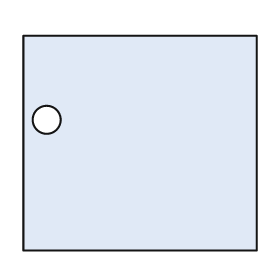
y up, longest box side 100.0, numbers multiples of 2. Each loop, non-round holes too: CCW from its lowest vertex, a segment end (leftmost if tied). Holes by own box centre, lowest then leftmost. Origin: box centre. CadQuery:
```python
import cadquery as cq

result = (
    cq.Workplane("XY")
    .moveTo(-50.0, -46.0)
    .lineTo(50.0, -46.0)
    .lineTo(50.0, 46.0)
    .lineTo(-50.0, 46.0)
    .close()
    .moveTo(-40.0, 10.0)
    .circle(6.0)
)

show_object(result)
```